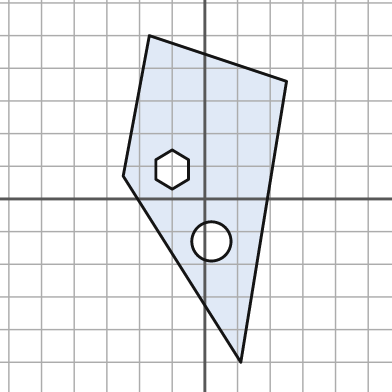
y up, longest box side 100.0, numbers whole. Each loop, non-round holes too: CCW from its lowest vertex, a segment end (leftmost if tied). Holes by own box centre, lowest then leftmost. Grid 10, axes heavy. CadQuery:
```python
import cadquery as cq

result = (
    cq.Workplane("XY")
    .moveTo(11.0, -50.0)
    .lineTo(25.0, 36.0)
    .lineTo(-17.0, 50.0)
    .lineTo(-25.0, 7.0)
    .close()
    .moveTo(2.0, -13.0)
    .circle(6.0)
    .moveTo(-10.0, 3.0)
    .lineTo(-5.0, 6.0)
    .lineTo(-5.0, 12.0)
    .lineTo(-10.0, 15.0)
    .lineTo(-15.0, 12.0)
    .lineTo(-15.0, 6.0)
    .close()
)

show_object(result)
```